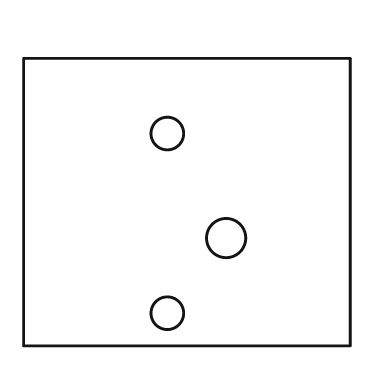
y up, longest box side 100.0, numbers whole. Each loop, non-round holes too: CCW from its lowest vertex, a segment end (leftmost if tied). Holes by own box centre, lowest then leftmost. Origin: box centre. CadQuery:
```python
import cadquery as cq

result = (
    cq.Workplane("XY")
    .moveTo(-50.0, -44.0)
    .lineTo(50.0, -44.0)
    .lineTo(50.0, 44.0)
    .lineTo(-50.0, 44.0)
    .close()
    .moveTo(-6.0, -34.0)
    .circle(5.0)
    .moveTo(12.0, -11.0)
    .circle(6.0)
    .moveTo(-6.0, 21.0)
    .circle(5.0)
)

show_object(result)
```